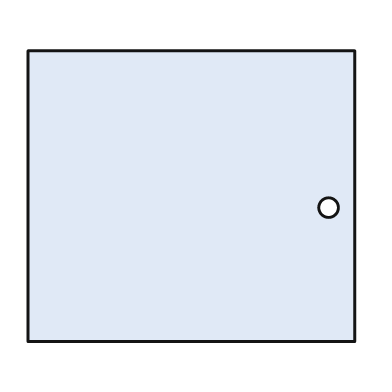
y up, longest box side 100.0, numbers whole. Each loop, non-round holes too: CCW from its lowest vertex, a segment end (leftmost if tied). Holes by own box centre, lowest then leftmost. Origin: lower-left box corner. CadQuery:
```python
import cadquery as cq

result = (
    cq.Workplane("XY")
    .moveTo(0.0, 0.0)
    .lineTo(100.0, 0.0)
    .lineTo(100.0, 89.0)
    .lineTo(0.0, 89.0)
    .close()
    .moveTo(92.0, 41.0)
    .circle(3.0)
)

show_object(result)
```